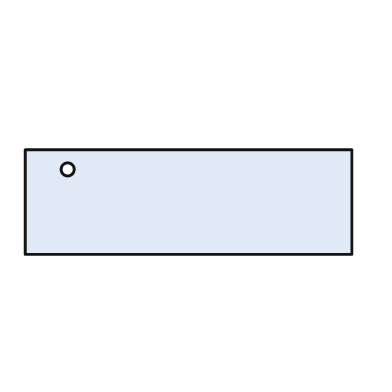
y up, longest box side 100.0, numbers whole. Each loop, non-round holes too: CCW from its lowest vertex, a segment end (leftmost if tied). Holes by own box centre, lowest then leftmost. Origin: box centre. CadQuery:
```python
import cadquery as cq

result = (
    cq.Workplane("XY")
    .moveTo(-50.0, -16.0)
    .lineTo(50.0, -16.0)
    .lineTo(50.0, 16.0)
    .lineTo(-50.0, 16.0)
    .close()
    .moveTo(-37.0, 10.0)
    .circle(2.0)
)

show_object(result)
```